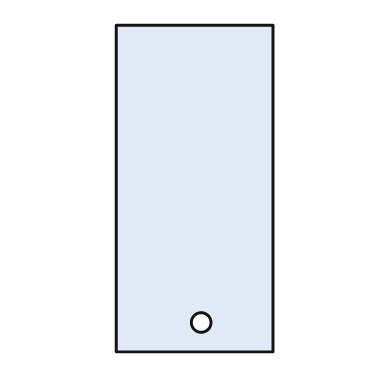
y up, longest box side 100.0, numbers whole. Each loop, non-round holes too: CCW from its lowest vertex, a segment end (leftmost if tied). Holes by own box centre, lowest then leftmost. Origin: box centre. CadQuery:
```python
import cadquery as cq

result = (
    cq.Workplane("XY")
    .moveTo(-24.0, -50.0)
    .lineTo(24.0, -50.0)
    .lineTo(24.0, 50.0)
    .lineTo(-24.0, 50.0)
    .close()
    .moveTo(2.0, -41.0)
    .circle(3.0)
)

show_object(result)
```